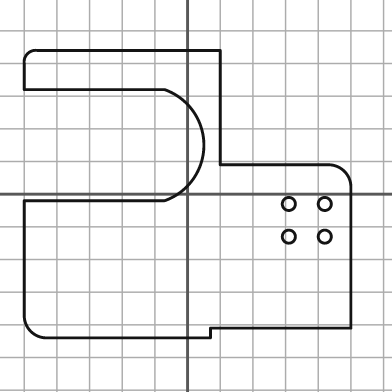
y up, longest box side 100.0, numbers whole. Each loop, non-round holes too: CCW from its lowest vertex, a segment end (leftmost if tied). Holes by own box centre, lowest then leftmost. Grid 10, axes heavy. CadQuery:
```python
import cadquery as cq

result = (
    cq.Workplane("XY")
    .moveTo(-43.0, -44.0)
    .lineTo(7.0, -44.0)
    .lineTo(7.0, -41.0)
    .lineTo(50.0, -41.0)
    .lineTo(50.0, 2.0)
    .threePointArc((48.0, 7.0), (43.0, 9.0))
    .lineTo(10.0, 9.0)
    .lineTo(10.0, 44.0)
    .lineTo(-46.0, 44.0)
    .threePointArc((-49.0, 43.0), (-50.0, 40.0))
    .lineTo(-50.0, 32.0)
    .lineTo(-7.0, 32.0)
    .threePointArc((5.0, 15.0), (-7.0, -2.0))
    .lineTo(-50.0, -2.0)
    .lineTo(-50.0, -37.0)
    .threePointArc((-48.0, -42.0), (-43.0, -44.0))
    .close()
    .moveTo(31.0, -13.0)
    .circle(2.0)
    .moveTo(42.0, -13.0)
    .circle(2.0)
    .moveTo(31.0, -3.0)
    .circle(2.0)
    .moveTo(42.0, -3.0)
    .circle(2.0)
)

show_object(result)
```